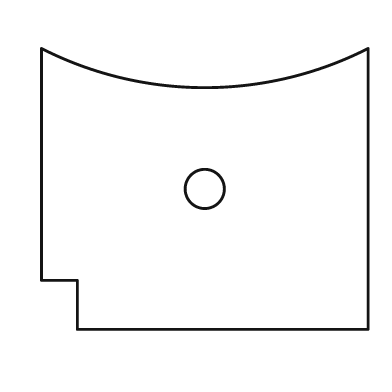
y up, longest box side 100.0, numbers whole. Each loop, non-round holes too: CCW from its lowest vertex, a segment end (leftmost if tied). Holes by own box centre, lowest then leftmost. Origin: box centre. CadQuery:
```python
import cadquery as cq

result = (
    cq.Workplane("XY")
    .moveTo(-39.0, -43.0)
    .lineTo(50.0, -43.0)
    .lineTo(50.0, 43.0)
    .threePointArc((0.0, 31.0), (-50.0, 43.0))
    .lineTo(-50.0, -28.0)
    .lineTo(-39.0, -28.0)
    .close()
    .moveTo(0.0, 0.0)
    .circle(6.0)
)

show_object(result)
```